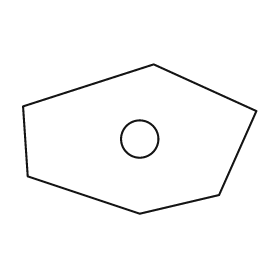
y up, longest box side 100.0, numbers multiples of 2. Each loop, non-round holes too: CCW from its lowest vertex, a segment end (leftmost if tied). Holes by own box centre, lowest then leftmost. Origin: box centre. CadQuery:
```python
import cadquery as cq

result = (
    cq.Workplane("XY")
    .moveTo(0.0, -32.0)
    .lineTo(34.0, -24.0)
    .lineTo(50.0, 12.0)
    .lineTo(6.0, 32.0)
    .lineTo(-50.0, 14.0)
    .lineTo(-48.0, -16.0)
    .close()
    .moveTo(0.0, 0.0)
    .circle(8.0)
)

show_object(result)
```